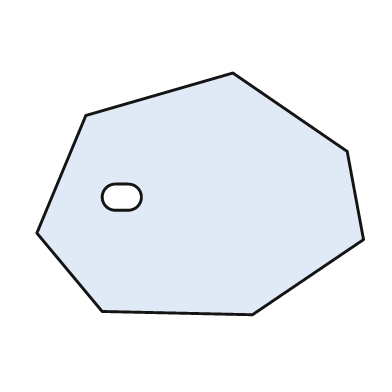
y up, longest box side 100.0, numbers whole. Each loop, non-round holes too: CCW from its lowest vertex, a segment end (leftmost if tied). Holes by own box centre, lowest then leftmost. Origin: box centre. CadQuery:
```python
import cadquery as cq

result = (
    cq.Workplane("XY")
    .moveTo(16.0, -37.0)
    .lineTo(50.0, -14.0)
    .lineTo(45.0, 13.0)
    .lineTo(10.0, 37.0)
    .lineTo(-35.0, 24.0)
    .lineTo(-50.0, -12.0)
    .lineTo(-30.0, -36.0)
    .close()
    .moveTo(-26.0, -5.0)
    .lineTo(-22.0, -5.0)
    .threePointArc((-18.0, -1.0), (-22.0, 3.0))
    .lineTo(-26.0, 3.0)
    .threePointArc((-30.0, -1.0), (-26.0, -5.0))
    .close()
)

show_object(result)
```